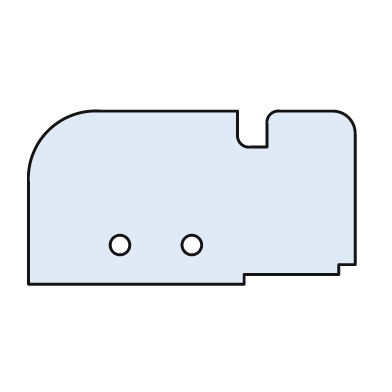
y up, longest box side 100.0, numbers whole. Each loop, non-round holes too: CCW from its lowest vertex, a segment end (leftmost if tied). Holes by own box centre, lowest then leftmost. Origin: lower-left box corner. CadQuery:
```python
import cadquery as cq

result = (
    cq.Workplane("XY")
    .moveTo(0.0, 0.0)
    .lineTo(66.0, 0.0)
    .lineTo(66.0, 3.0)
    .lineTo(95.0, 3.0)
    .lineTo(95.0, 6.0)
    .lineTo(100.0, 6.0)
    .lineTo(100.0, 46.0)
    .threePointArc((98.0, 51.0), (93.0, 53.0))
    .lineTo(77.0, 53.0)
    .threePointArc((74.0, 52.0), (73.0, 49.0))
    .lineTo(73.0, 42.0)
    .lineTo(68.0, 42.0)
    .threePointArc((65.0, 43.0), (64.0, 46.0))
    .lineTo(64.0, 53.0)
    .lineTo(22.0, 53.0)
    .threePointArc((6.0, 47.0), (0.0, 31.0))
    .close()
    .moveTo(28.0, 12.0)
    .circle(3.0)
    .moveTo(50.0, 12.0)
    .circle(3.0)
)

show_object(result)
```